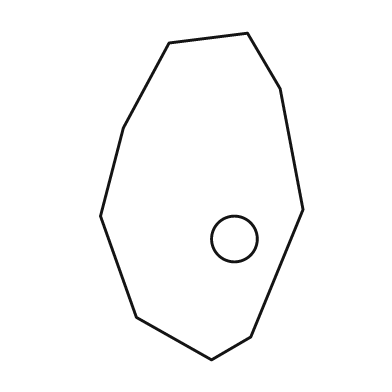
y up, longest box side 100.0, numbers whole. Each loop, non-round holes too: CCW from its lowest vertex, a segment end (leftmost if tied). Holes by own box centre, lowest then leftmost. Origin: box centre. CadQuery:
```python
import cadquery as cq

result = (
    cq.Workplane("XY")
    .moveTo(3.0, -50.0)
    .lineTo(15.0, -43.0)
    .lineTo(31.0, -4.0)
    .lineTo(24.0, 33.0)
    .lineTo(14.0, 50.0)
    .lineTo(-10.0, 47.0)
    .lineTo(-24.0, 21.0)
    .lineTo(-31.0, -6.0)
    .lineTo(-20.0, -37.0)
    .close()
    .moveTo(10.0, -13.0)
    .circle(7.0)
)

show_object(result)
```